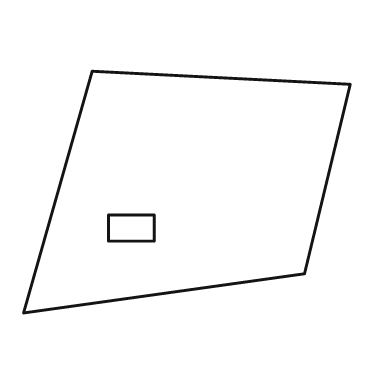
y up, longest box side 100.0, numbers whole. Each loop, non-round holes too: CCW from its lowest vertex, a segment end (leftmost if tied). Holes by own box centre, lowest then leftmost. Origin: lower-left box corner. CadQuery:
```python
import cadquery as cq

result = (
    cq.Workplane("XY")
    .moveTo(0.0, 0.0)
    .lineTo(86.0, 12.0)
    .lineTo(100.0, 70.0)
    .lineTo(21.0, 74.0)
    .close()
    .moveTo(26.0, 22.0)
    .lineTo(40.0, 22.0)
    .lineTo(40.0, 30.0)
    .lineTo(26.0, 30.0)
    .close()
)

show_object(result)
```